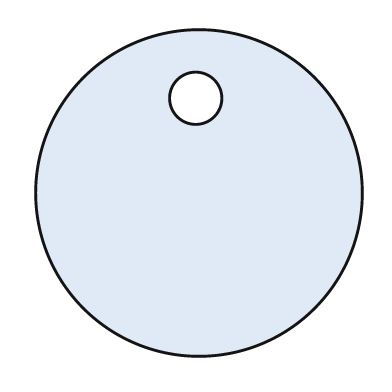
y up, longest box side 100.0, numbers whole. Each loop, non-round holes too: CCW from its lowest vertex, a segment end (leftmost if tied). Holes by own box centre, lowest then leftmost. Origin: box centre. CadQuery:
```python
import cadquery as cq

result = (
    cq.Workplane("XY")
    .moveTo(0.0, 0.0)
    .circle(50.0)
    .moveTo(-1.0, 29.0)
    .circle(8.0)
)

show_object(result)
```